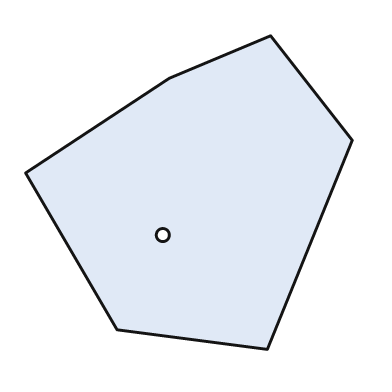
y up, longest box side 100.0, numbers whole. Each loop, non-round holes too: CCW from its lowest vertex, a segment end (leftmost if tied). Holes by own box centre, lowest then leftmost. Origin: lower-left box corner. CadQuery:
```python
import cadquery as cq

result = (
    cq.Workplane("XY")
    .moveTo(74.0, 0.0)
    .lineTo(100.0, 64.0)
    .lineTo(75.0, 96.0)
    .lineTo(44.0, 83.0)
    .lineTo(0.0, 54.0)
    .lineTo(28.0, 6.0)
    .close()
    .moveTo(42.0, 35.0)
    .circle(2.0)
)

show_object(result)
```